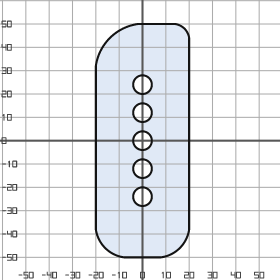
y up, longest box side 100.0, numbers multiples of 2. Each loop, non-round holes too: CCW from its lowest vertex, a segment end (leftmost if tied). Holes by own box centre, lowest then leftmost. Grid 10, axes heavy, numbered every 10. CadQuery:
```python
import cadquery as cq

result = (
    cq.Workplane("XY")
    .moveTo(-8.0, -50.0)
    .lineTo(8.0, -50.0)
    .threePointArc((16.0, -46.0), (20.0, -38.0))
    .lineTo(20.0, 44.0)
    .threePointArc((18.0, 48.0), (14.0, 50.0))
    .lineTo(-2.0, 50.0)
    .threePointArc((-14.0, 44.0), (-20.0, 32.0))
    .lineTo(-20.0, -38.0)
    .threePointArc((-16.0, -46.0), (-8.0, -50.0))
    .close()
    .moveTo(0.0, -24.0)
    .circle(4.0)
    .moveTo(0.0, -12.0)
    .circle(4.0)
    .moveTo(0.0, 0.0)
    .circle(4.0)
    .moveTo(0.0, 12.0)
    .circle(4.0)
    .moveTo(0.0, 24.0)
    .circle(4.0)
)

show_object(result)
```